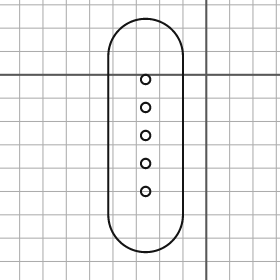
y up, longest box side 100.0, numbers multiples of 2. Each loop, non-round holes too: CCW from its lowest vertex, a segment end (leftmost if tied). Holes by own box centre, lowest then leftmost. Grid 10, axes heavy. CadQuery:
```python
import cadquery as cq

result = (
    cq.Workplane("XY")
    .moveTo(-42.0, -60.0)
    .threePointArc((-26.0, -76.0), (-10.0, -60.0))
    .lineTo(-10.0, 8.0)
    .threePointArc((-26.0, 24.0), (-42.0, 8.0))
    .close()
    .moveTo(-26.0, -50.0)
    .circle(2.0)
    .moveTo(-26.0, -38.0)
    .circle(2.0)
    .moveTo(-26.0, -26.0)
    .circle(2.0)
    .moveTo(-26.0, -14.0)
    .circle(2.0)
    .moveTo(-26.0, -2.0)
    .circle(2.0)
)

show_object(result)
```